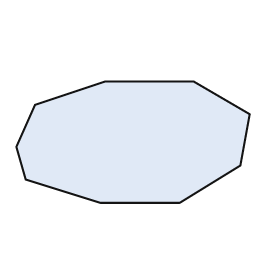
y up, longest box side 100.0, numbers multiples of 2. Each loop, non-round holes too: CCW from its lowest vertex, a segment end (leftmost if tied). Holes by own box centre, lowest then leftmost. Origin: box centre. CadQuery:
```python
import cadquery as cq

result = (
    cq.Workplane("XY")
    .moveTo(-14.0, -26.0)
    .lineTo(20.0, -26.0)
    .lineTo(46.0, -10.0)
    .lineTo(50.0, 12.0)
    .lineTo(26.0, 26.0)
    .lineTo(-12.0, 26.0)
    .lineTo(-42.0, 16.0)
    .lineTo(-50.0, -2.0)
    .lineTo(-46.0, -16.0)
    .close()
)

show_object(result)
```